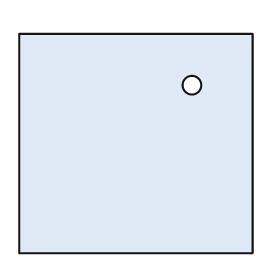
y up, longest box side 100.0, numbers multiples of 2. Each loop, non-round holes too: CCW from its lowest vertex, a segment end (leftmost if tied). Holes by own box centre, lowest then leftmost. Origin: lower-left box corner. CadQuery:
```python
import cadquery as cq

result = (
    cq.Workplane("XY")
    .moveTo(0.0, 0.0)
    .lineTo(100.0, 0.0)
    .lineTo(100.0, 94.0)
    .lineTo(0.0, 94.0)
    .close()
    .moveTo(74.0, 72.0)
    .circle(4.0)
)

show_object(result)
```